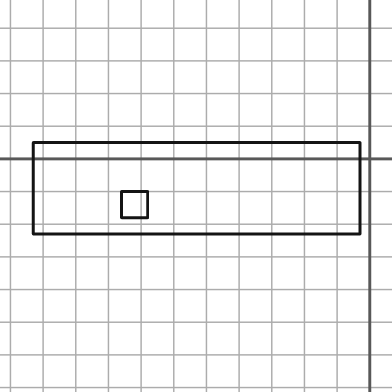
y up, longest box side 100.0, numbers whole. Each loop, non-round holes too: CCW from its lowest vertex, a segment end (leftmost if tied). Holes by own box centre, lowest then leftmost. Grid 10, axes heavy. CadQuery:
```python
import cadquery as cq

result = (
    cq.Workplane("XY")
    .moveTo(-103.0, -23.0)
    .lineTo(-3.0, -23.0)
    .lineTo(-3.0, 5.0)
    .lineTo(-103.0, 5.0)
    .close()
    .moveTo(-76.0, -18.0)
    .lineTo(-68.0, -18.0)
    .lineTo(-68.0, -10.0)
    .lineTo(-76.0, -10.0)
    .close()
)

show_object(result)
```